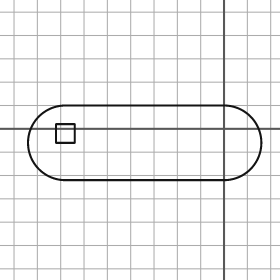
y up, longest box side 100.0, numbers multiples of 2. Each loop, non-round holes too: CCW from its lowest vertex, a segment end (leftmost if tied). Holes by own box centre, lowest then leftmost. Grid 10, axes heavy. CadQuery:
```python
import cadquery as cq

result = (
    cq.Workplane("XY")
    .moveTo(-68.0, -22.0)
    .lineTo(0.0, -22.0)
    .threePointArc((16.0, -6.0), (0.0, 10.0))
    .lineTo(-68.0, 10.0)
    .threePointArc((-84.0, -6.0), (-68.0, -22.0))
    .close()
    .moveTo(-72.0, -6.0)
    .lineTo(-64.0, -6.0)
    .lineTo(-64.0, 2.0)
    .lineTo(-72.0, 2.0)
    .close()
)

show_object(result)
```